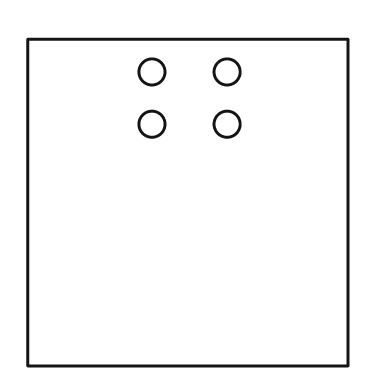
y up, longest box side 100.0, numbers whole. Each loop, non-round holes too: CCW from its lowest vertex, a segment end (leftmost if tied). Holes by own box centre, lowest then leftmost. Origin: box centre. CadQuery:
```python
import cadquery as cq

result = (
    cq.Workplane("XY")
    .moveTo(-49.0, -50.0)
    .lineTo(49.0, -50.0)
    .lineTo(49.0, 50.0)
    .lineTo(-49.0, 50.0)
    .close()
    .moveTo(-11.0, 24.0)
    .circle(4.0)
    .moveTo(12.0, 24.0)
    .circle(4.0)
    .moveTo(-11.0, 40.0)
    .circle(4.0)
    .moveTo(12.0, 40.0)
    .circle(4.0)
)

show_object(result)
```